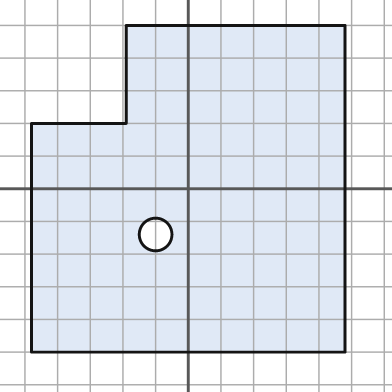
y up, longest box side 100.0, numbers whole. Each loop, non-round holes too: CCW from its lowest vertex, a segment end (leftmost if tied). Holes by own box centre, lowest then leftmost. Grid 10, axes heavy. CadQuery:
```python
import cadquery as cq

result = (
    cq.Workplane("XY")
    .moveTo(-48.0, -50.0)
    .lineTo(48.0, -50.0)
    .lineTo(48.0, 50.0)
    .lineTo(-19.0, 50.0)
    .lineTo(-19.0, 20.0)
    .lineTo(-48.0, 20.0)
    .close()
    .moveTo(-10.0, -14.0)
    .circle(5.0)
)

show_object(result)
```